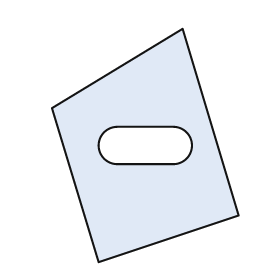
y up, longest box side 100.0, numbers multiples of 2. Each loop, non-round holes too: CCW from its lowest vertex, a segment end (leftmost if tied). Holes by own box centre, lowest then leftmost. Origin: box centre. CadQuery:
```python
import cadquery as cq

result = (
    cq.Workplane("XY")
    .moveTo(-20.0, -50.0)
    .lineTo(40.0, -30.0)
    .lineTo(16.0, 50.0)
    .lineTo(-40.0, 16.0)
    .close()
    .moveTo(-12.0, -8.0)
    .lineTo(12.0, -8.0)
    .threePointArc((20.0, 0.0), (12.0, 8.0))
    .lineTo(-12.0, 8.0)
    .threePointArc((-20.0, 0.0), (-12.0, -8.0))
    .close()
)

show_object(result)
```